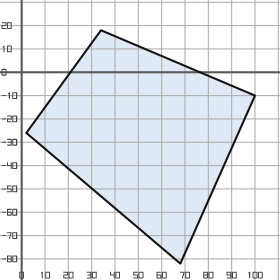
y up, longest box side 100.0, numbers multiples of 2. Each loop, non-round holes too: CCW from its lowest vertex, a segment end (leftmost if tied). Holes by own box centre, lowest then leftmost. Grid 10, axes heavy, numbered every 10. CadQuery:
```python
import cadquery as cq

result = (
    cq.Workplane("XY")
    .moveTo(68.0, -82.0)
    .lineTo(100.0, -10.0)
    .lineTo(34.0, 18.0)
    .lineTo(2.0, -26.0)
    .close()
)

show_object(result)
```